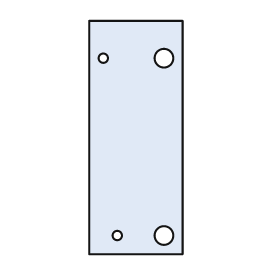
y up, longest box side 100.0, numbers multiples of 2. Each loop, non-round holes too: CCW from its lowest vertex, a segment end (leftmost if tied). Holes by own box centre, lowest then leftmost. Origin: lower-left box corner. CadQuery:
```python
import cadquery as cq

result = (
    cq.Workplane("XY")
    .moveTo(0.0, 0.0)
    .lineTo(40.0, 0.0)
    .lineTo(40.0, 100.0)
    .lineTo(0.0, 100.0)
    .close()
    .moveTo(12.0, 8.0)
    .circle(2.0)
    .moveTo(32.0, 8.0)
    .circle(4.0)
    .moveTo(6.0, 84.0)
    .circle(2.0)
    .moveTo(32.0, 84.0)
    .circle(4.0)
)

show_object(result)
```